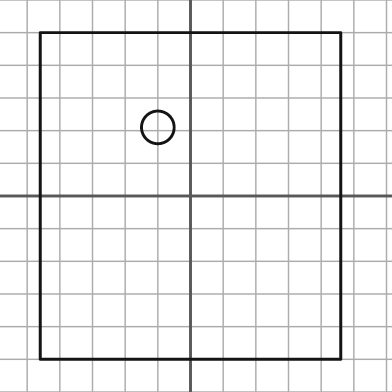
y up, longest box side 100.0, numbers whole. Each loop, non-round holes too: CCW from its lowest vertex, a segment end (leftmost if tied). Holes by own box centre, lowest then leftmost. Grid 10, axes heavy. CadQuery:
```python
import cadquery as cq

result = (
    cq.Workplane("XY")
    .moveTo(-46.0, -50.0)
    .lineTo(46.0, -50.0)
    .lineTo(46.0, 50.0)
    .lineTo(-46.0, 50.0)
    .close()
    .moveTo(-10.0, 21.0)
    .circle(5.0)
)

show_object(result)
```